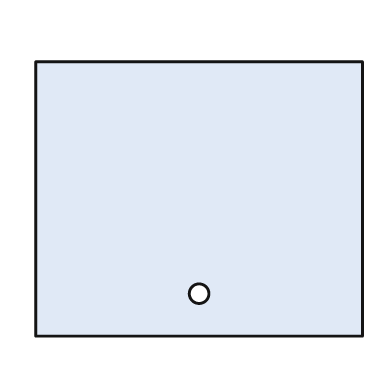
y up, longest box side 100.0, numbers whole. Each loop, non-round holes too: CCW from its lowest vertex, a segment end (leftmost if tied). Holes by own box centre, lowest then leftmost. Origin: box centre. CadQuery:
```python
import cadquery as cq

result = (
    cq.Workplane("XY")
    .moveTo(-50.0, -42.0)
    .lineTo(50.0, -42.0)
    .lineTo(50.0, 42.0)
    .lineTo(-50.0, 42.0)
    .close()
    .moveTo(0.0, -29.0)
    .circle(3.0)
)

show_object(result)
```